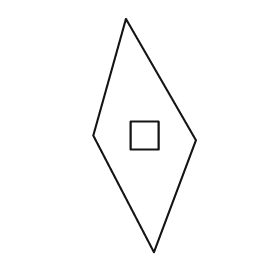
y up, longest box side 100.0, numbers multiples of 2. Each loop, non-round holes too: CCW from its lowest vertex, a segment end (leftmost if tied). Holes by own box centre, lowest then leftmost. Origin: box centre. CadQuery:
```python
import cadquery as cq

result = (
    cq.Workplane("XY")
    .moveTo(4.0, -50.0)
    .lineTo(22.0, -2.0)
    .lineTo(-8.0, 50.0)
    .lineTo(-22.0, 0.0)
    .close()
    .moveTo(-6.0, -6.0)
    .lineTo(6.0, -6.0)
    .lineTo(6.0, 6.0)
    .lineTo(-6.0, 6.0)
    .close()
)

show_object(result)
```